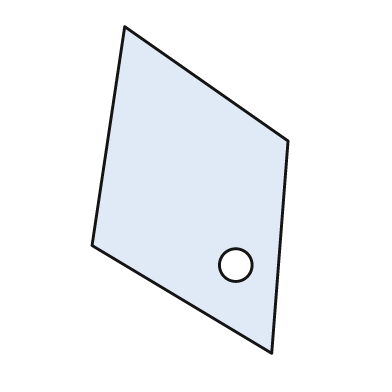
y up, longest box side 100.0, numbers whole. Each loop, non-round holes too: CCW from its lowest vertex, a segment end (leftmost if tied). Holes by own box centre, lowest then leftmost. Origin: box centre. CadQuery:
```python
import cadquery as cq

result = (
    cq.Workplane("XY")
    .moveTo(25.0, -50.0)
    .lineTo(30.0, 15.0)
    .lineTo(-20.0, 50.0)
    .lineTo(-30.0, -17.0)
    .close()
    .moveTo(14.0, -23.0)
    .circle(5.0)
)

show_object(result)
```